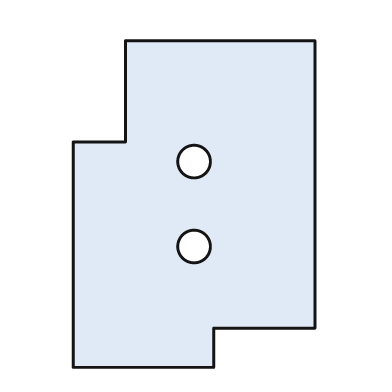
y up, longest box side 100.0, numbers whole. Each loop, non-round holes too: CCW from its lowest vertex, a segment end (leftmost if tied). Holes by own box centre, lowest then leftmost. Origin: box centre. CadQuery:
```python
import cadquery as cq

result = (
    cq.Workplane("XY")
    .moveTo(-37.0, -50.0)
    .lineTo(6.0, -50.0)
    .lineTo(6.0, -38.0)
    .lineTo(37.0, -38.0)
    .lineTo(37.0, 50.0)
    .lineTo(-21.0, 50.0)
    .lineTo(-21.0, 19.0)
    .lineTo(-37.0, 19.0)
    .close()
    .moveTo(0.0, -13.0)
    .circle(5.0)
    .moveTo(0.0, 13.0)
    .circle(5.0)
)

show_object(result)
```